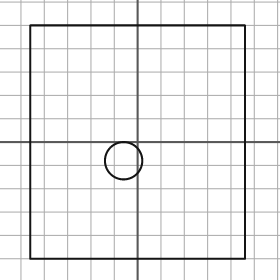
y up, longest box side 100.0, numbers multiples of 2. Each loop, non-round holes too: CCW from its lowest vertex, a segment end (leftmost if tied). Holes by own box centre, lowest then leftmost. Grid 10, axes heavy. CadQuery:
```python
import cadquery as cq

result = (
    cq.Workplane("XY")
    .moveTo(-46.0, -50.0)
    .lineTo(46.0, -50.0)
    .lineTo(46.0, 50.0)
    .lineTo(-46.0, 50.0)
    .close()
    .moveTo(-6.0, -8.0)
    .circle(8.0)
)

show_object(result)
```